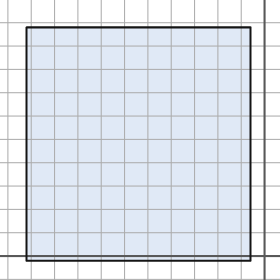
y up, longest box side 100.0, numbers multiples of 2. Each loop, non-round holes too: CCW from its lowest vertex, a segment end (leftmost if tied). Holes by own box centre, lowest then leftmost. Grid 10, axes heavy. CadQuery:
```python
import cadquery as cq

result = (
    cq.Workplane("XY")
    .moveTo(-102.0, -2.0)
    .lineTo(-6.0, -2.0)
    .lineTo(-6.0, 98.0)
    .lineTo(-102.0, 98.0)
    .close()
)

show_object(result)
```